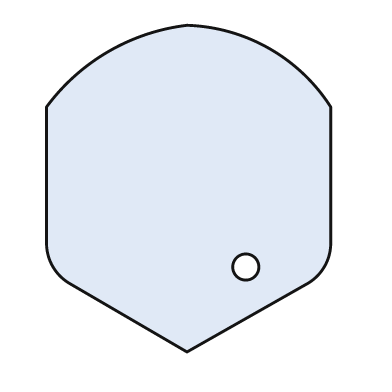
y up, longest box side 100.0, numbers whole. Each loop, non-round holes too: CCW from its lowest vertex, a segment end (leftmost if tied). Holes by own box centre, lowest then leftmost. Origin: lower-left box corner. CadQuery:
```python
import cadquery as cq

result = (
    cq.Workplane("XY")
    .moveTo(43.0, 0.0)
    .lineTo(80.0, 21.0)
    .threePointArc((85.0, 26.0), (87.0, 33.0))
    .lineTo(87.0, 75.0)
    .threePointArc((68.0, 93.0), (43.0, 100.0))
    .threePointArc((19.0, 92.0), (0.0, 75.0))
    .lineTo(0.0, 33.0)
    .threePointArc((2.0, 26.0), (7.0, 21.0))
    .close()
    .moveTo(61.0, 26.0)
    .circle(4.0)
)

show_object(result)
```